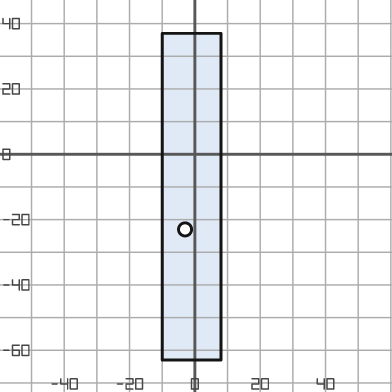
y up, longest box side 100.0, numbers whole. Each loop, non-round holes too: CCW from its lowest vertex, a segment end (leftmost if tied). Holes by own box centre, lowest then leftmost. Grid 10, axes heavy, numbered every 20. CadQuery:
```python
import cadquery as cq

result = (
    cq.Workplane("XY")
    .moveTo(-10.0, -63.0)
    .lineTo(8.0, -63.0)
    .lineTo(8.0, 37.0)
    .lineTo(-10.0, 37.0)
    .close()
    .moveTo(-3.0, -23.0)
    .circle(2.0)
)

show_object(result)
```